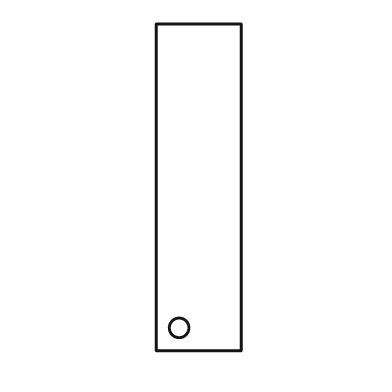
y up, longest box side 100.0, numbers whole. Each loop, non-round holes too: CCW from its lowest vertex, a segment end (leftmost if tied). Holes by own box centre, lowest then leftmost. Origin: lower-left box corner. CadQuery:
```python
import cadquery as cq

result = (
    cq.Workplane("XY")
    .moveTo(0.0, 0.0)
    .lineTo(26.0, 0.0)
    .lineTo(26.0, 100.0)
    .lineTo(0.0, 100.0)
    .close()
    .moveTo(7.0, 7.0)
    .circle(3.0)
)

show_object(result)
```